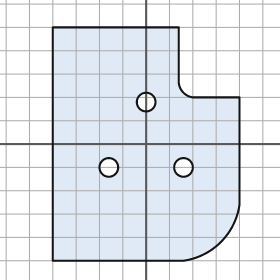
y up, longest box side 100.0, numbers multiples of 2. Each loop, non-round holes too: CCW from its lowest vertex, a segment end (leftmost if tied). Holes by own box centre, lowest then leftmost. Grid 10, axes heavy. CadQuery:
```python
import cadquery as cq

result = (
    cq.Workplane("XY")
    .moveTo(-40.0, -50.0)
    .lineTo(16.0, -50.0)
    .threePointArc((32.0, -42.0), (40.0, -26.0))
    .lineTo(40.0, 20.0)
    .lineTo(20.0, 20.0)
    .threePointArc((16.0, 22.0), (14.0, 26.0))
    .lineTo(14.0, 50.0)
    .lineTo(-40.0, 50.0)
    .close()
    .moveTo(-16.0, -10.0)
    .circle(4.0)
    .moveTo(16.0, -10.0)
    .circle(4.0)
    .moveTo(0.0, 18.0)
    .circle(4.0)
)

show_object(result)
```